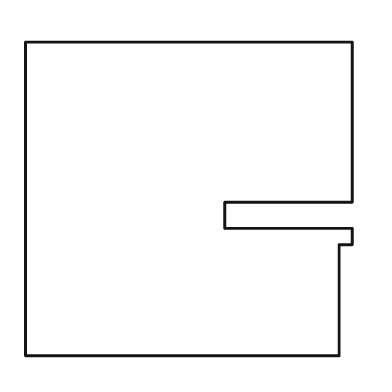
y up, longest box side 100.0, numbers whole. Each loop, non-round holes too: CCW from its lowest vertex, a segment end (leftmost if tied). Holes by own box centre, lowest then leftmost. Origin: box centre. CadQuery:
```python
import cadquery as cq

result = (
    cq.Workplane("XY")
    .moveTo(-50.0, -48.0)
    .lineTo(46.0, -48.0)
    .lineTo(46.0, -14.0)
    .lineTo(50.0, -14.0)
    .lineTo(50.0, -9.0)
    .lineTo(11.0, -9.0)
    .lineTo(11.0, -1.0)
    .lineTo(50.0, -1.0)
    .lineTo(50.0, 48.0)
    .lineTo(-50.0, 48.0)
    .close()
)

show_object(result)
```